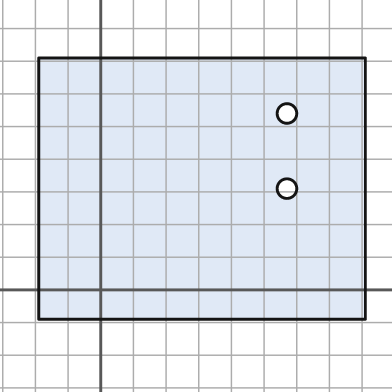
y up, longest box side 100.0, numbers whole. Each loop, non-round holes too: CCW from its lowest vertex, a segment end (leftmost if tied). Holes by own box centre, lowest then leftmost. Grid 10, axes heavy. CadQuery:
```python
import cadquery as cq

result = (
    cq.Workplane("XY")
    .moveTo(-19.0, -9.0)
    .lineTo(81.0, -9.0)
    .lineTo(81.0, 71.0)
    .lineTo(-19.0, 71.0)
    .close()
    .moveTo(57.0, 31.0)
    .circle(3.0)
    .moveTo(57.0, 54.0)
    .circle(3.0)
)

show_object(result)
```